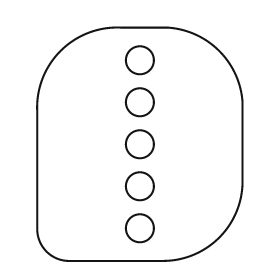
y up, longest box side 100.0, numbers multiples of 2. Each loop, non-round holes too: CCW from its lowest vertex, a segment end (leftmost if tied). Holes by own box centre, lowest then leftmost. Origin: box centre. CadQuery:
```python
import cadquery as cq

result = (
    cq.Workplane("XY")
    .moveTo(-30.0, -50.0)
    .lineTo(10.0, -50.0)
    .threePointArc((34.0, -40.0), (44.0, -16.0))
    .lineTo(44.0, 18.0)
    .threePointArc((34.0, 40.0), (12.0, 50.0))
    .lineTo(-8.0, 50.0)
    .threePointArc((-34.0, 40.0), (-44.0, 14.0))
    .lineTo(-44.0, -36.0)
    .threePointArc((-40.0, -46.0), (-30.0, -50.0))
    .close()
    .moveTo(0.0, -36.0)
    .circle(6.0)
    .moveTo(0.0, -18.0)
    .circle(6.0)
    .moveTo(0.0, 0.0)
    .circle(6.0)
    .moveTo(0.0, 18.0)
    .circle(6.0)
    .moveTo(0.0, 36.0)
    .circle(6.0)
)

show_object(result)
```